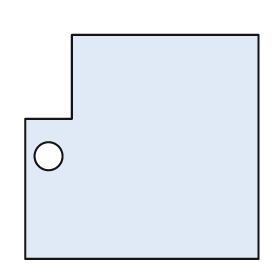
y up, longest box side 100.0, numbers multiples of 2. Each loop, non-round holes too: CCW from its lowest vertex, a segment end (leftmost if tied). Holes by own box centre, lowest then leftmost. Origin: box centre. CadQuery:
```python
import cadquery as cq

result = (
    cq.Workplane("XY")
    .moveTo(-50.0, -48.0)
    .lineTo(50.0, -48.0)
    .lineTo(50.0, 48.0)
    .lineTo(-30.0, 48.0)
    .lineTo(-30.0, 12.0)
    .lineTo(-50.0, 12.0)
    .close()
    .moveTo(-40.0, -4.0)
    .circle(6.0)
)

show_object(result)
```